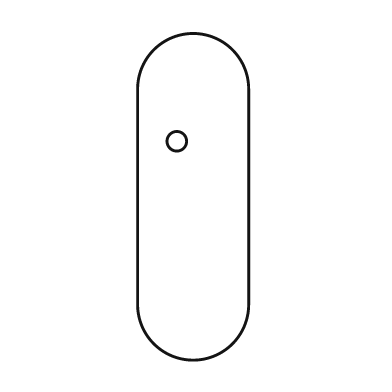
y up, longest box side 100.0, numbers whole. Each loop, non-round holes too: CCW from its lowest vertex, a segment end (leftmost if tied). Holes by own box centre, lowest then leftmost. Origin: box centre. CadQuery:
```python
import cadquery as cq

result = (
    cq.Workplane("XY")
    .moveTo(-17.0, -33.0)
    .threePointArc((0.0, -50.0), (17.0, -33.0))
    .lineTo(17.0, 33.0)
    .threePointArc((0.0, 50.0), (-17.0, 33.0))
    .close()
    .moveTo(-5.0, 17.0)
    .circle(3.0)
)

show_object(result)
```